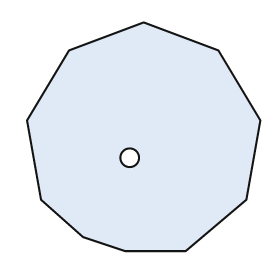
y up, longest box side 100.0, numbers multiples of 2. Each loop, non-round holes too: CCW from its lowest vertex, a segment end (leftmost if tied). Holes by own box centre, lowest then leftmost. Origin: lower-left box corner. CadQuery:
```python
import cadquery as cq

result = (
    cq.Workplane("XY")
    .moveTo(42.0, 0.0)
    .lineTo(68.0, 0.0)
    .lineTo(94.0, 22.0)
    .lineTo(100.0, 56.0)
    .lineTo(82.0, 86.0)
    .lineTo(50.0, 98.0)
    .lineTo(18.0, 86.0)
    .lineTo(0.0, 56.0)
    .lineTo(6.0, 22.0)
    .lineTo(24.0, 6.0)
    .close()
    .moveTo(44.0, 40.0)
    .circle(4.0)
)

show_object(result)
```